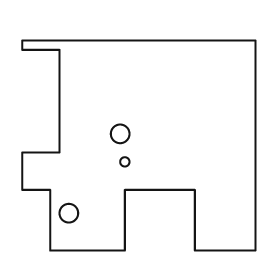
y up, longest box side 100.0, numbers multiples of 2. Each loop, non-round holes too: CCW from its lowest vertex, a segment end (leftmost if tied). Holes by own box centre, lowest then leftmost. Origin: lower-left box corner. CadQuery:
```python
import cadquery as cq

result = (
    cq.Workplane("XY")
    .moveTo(12.0, 0.0)
    .lineTo(44.0, 0.0)
    .lineTo(44.0, 26.0)
    .lineTo(74.0, 26.0)
    .lineTo(74.0, 0.0)
    .lineTo(100.0, 0.0)
    .lineTo(100.0, 90.0)
    .lineTo(0.0, 90.0)
    .lineTo(0.0, 86.0)
    .lineTo(16.0, 86.0)
    .lineTo(16.0, 42.0)
    .lineTo(0.0, 42.0)
    .lineTo(0.0, 26.0)
    .lineTo(12.0, 26.0)
    .close()
    .moveTo(20.0, 16.0)
    .circle(4.0)
    .moveTo(44.0, 38.0)
    .circle(2.0)
    .moveTo(42.0, 50.0)
    .circle(4.0)
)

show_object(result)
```